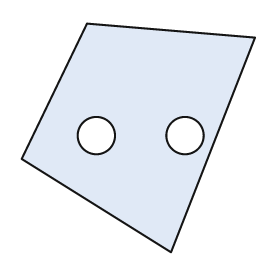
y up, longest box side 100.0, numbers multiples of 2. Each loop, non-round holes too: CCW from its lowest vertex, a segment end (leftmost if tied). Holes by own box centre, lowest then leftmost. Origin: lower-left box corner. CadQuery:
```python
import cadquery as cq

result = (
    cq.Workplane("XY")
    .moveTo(64.0, 0.0)
    .lineTo(100.0, 92.0)
    .lineTo(28.0, 98.0)
    .lineTo(0.0, 40.0)
    .close()
    .moveTo(32.0, 50.0)
    .circle(8.0)
    .moveTo(70.0, 50.0)
    .circle(8.0)
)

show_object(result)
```